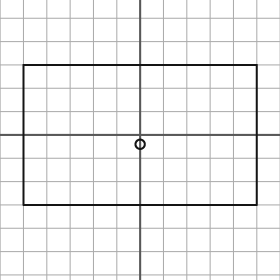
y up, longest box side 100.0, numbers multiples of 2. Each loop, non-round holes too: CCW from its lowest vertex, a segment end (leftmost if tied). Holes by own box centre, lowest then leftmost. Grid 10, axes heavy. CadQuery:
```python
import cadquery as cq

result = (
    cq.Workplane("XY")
    .moveTo(-50.0, -30.0)
    .lineTo(50.0, -30.0)
    .lineTo(50.0, 30.0)
    .lineTo(-50.0, 30.0)
    .close()
    .moveTo(0.0, -4.0)
    .circle(2.0)
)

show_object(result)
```